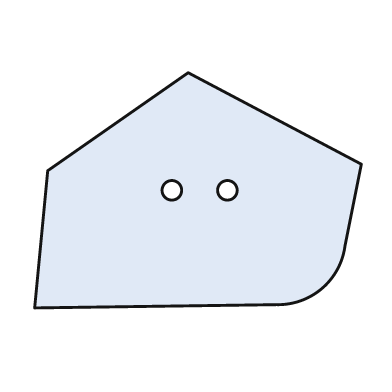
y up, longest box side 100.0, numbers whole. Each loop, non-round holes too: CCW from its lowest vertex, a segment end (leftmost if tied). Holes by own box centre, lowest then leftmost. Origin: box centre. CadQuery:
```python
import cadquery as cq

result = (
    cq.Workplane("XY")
    .moveTo(-50.0, -36.0)
    .lineTo(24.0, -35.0)
    .threePointArc((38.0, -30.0), (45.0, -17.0))
    .lineTo(50.0, 8.0)
    .lineTo(-3.0, 36.0)
    .lineTo(-46.0, 6.0)
    .close()
    .moveTo(-8.0, 0.0)
    .circle(3.0)
    .moveTo(9.0, 0.0)
    .circle(3.0)
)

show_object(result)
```